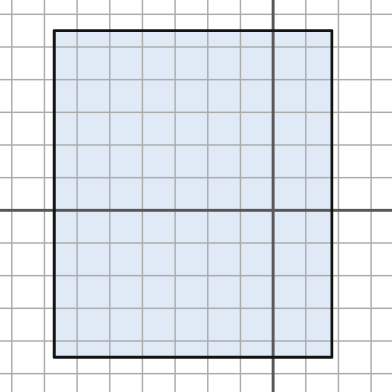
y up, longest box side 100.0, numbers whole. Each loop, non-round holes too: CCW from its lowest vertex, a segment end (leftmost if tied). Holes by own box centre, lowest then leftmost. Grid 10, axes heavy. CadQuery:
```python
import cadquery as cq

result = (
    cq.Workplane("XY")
    .moveTo(-67.0, -45.0)
    .lineTo(18.0, -45.0)
    .lineTo(18.0, 55.0)
    .lineTo(-67.0, 55.0)
    .close()
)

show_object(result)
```